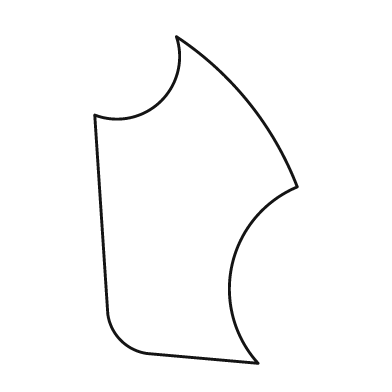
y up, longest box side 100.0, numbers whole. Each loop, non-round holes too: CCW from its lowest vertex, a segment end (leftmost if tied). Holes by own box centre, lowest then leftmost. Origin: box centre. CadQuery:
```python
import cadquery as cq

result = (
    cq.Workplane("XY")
    .moveTo(19.0, -50.0)
    .threePointArc((11.0, -20.0), (31.0, 4.0))
    .threePointArc((16.0, 30.0), (-6.0, 50.0))
    .threePointArc((-11.0, 30.0), (-31.0, 26.0))
    .lineTo(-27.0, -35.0)
    .threePointArc((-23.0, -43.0), (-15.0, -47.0))
    .close()
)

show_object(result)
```